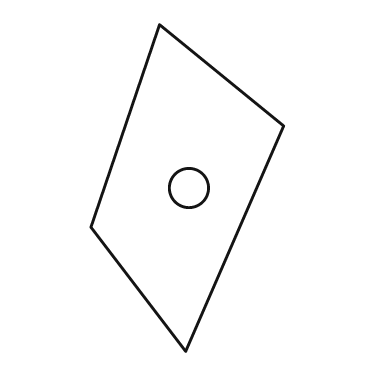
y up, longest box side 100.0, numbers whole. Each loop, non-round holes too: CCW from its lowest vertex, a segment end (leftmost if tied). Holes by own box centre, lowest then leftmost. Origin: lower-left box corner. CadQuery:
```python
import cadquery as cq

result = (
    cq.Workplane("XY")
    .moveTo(29.0, 0.0)
    .lineTo(59.0, 69.0)
    .lineTo(21.0, 100.0)
    .lineTo(0.0, 38.0)
    .close()
    .moveTo(30.0, 50.0)
    .circle(6.0)
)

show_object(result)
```